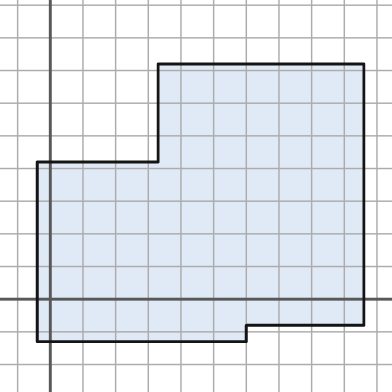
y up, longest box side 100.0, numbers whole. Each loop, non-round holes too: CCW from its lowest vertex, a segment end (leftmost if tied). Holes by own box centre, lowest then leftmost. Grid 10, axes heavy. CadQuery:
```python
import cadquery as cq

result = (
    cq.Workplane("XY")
    .moveTo(-4.0, -13.0)
    .lineTo(60.0, -13.0)
    .lineTo(60.0, -8.0)
    .lineTo(96.0, -8.0)
    .lineTo(96.0, 72.0)
    .lineTo(33.0, 72.0)
    .lineTo(33.0, 42.0)
    .lineTo(-4.0, 42.0)
    .close()
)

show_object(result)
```